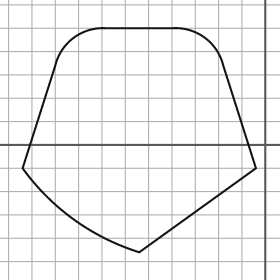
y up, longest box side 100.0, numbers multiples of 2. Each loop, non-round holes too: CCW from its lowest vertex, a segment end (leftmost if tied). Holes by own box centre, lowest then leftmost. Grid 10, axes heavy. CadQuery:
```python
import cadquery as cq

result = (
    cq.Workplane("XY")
    .moveTo(-54.0, -46.0)
    .lineTo(-4.0, -10.0)
    .lineTo(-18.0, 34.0)
    .threePointArc((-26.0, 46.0), (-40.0, 50.0))
    .lineTo(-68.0, 50.0)
    .threePointArc((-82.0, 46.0), (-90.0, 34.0))
    .lineTo(-104.0, -10.0)
    .threePointArc((-82.0, -32.0), (-54.0, -46.0))
    .close()
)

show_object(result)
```